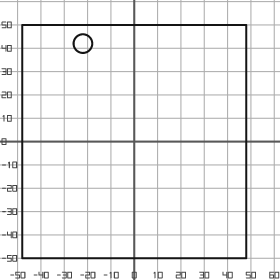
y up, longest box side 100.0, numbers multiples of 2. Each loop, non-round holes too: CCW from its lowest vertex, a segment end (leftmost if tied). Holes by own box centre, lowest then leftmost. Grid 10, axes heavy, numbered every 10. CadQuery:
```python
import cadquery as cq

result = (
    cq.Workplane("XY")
    .moveTo(-48.0, -50.0)
    .lineTo(48.0, -50.0)
    .lineTo(48.0, 50.0)
    .lineTo(-48.0, 50.0)
    .close()
    .moveTo(-22.0, 42.0)
    .circle(4.0)
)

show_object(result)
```